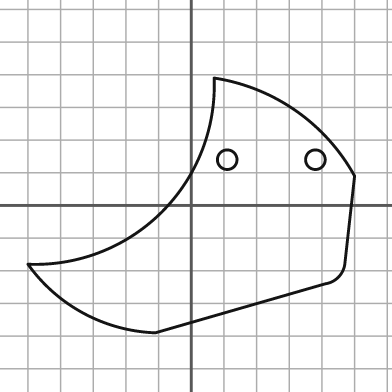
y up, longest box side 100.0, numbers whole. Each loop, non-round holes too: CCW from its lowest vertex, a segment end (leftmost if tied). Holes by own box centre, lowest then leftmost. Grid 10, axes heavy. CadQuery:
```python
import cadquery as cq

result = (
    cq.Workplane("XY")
    .moveTo(-11.0, -39.0)
    .lineTo(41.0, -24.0)
    .threePointArc((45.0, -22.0), (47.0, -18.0))
    .lineTo(50.0, 9.0)
    .threePointArc((32.0, 29.0), (7.0, 39.0))
    .threePointArc((-9.0, -2.0), (-50.0, -18.0))
    .threePointArc((-33.0, -33.0), (-11.0, -39.0))
    .close()
    .moveTo(11.0, 14.0)
    .circle(3.0)
    .moveTo(38.0, 14.0)
    .circle(3.0)
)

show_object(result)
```